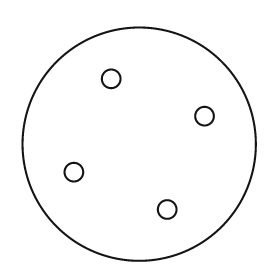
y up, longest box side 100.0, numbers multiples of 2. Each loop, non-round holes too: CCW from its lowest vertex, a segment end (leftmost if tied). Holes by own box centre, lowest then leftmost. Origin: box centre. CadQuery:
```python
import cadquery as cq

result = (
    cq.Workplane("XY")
    .moveTo(0.0, 0.0)
    .circle(50.0)
    .moveTo(12.0, -28.0)
    .circle(4.0)
    .moveTo(-28.0, -12.0)
    .circle(4.0)
    .moveTo(28.0, 12.0)
    .circle(4.0)
    .moveTo(-12.0, 28.0)
    .circle(4.0)
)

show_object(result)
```